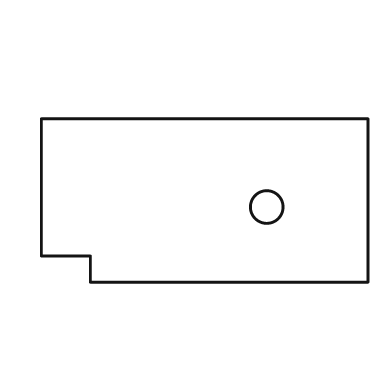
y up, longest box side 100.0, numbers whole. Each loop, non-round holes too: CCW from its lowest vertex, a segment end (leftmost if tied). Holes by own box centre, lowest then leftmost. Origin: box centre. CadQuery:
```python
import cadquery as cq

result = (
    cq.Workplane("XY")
    .moveTo(-35.0, -25.0)
    .lineTo(50.0, -25.0)
    .lineTo(50.0, 25.0)
    .lineTo(-50.0, 25.0)
    .lineTo(-50.0, -17.0)
    .lineTo(-35.0, -17.0)
    .close()
    .moveTo(19.0, -2.0)
    .circle(5.0)
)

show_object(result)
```